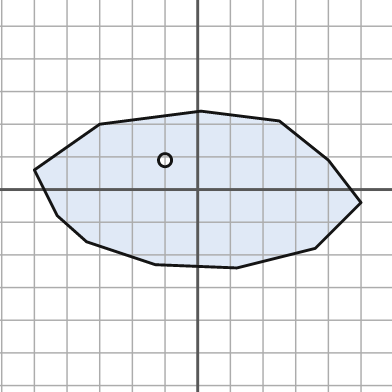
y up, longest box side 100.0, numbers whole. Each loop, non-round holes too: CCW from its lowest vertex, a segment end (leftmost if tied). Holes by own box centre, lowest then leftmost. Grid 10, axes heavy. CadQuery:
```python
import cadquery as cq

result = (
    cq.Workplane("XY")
    .moveTo(12.0, -24.0)
    .lineTo(36.0, -18.0)
    .lineTo(50.0, -4.0)
    .lineTo(40.0, 9.0)
    .lineTo(25.0, 21.0)
    .lineTo(1.0, 24.0)
    .lineTo(-30.0, 20.0)
    .lineTo(-50.0, 6.0)
    .lineTo(-43.0, -8.0)
    .lineTo(-34.0, -16.0)
    .lineTo(-13.0, -23.0)
    .close()
    .moveTo(-10.0, 9.0)
    .circle(2.0)
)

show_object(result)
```